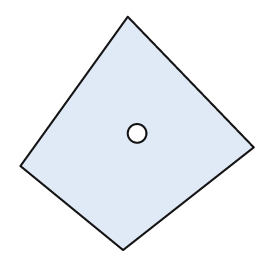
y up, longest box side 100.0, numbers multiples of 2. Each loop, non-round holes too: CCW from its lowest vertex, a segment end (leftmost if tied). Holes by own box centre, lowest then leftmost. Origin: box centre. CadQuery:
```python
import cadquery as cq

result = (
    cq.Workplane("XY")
    .moveTo(-6.0, -50.0)
    .lineTo(50.0, -6.0)
    .lineTo(-4.0, 50.0)
    .lineTo(-50.0, -14.0)
    .close()
    .moveTo(0.0, 0.0)
    .circle(4.0)
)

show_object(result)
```